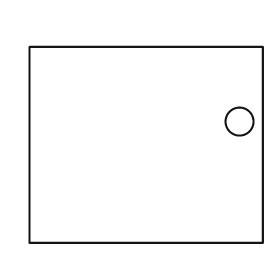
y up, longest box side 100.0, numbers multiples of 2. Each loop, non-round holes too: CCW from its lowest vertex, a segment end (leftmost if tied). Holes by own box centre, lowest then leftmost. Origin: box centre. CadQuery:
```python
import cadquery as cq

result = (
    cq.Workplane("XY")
    .moveTo(-50.0, -42.0)
    .lineTo(50.0, -42.0)
    .lineTo(50.0, 42.0)
    .lineTo(-50.0, 42.0)
    .close()
    .moveTo(40.0, 10.0)
    .circle(6.0)
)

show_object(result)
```